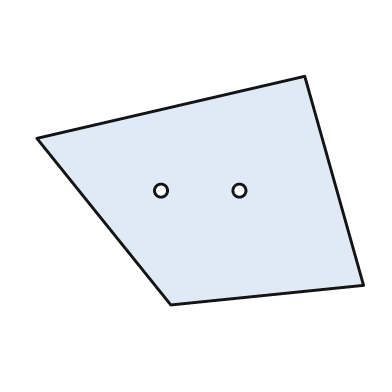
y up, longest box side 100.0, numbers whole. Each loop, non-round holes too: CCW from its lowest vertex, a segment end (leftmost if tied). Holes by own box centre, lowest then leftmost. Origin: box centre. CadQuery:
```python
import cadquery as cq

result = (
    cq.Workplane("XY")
    .moveTo(-9.0, -35.0)
    .lineTo(50.0, -29.0)
    .lineTo(32.0, 35.0)
    .lineTo(-50.0, 16.0)
    .close()
    .moveTo(-12.0, 0.0)
    .circle(2.0)
    .moveTo(12.0, 0.0)
    .circle(2.0)
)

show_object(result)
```